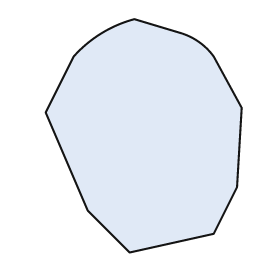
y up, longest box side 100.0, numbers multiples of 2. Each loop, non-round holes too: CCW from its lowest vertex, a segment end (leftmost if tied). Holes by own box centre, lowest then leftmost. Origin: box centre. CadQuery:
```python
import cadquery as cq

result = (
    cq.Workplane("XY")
    .moveTo(-6.0, -50.0)
    .lineTo(30.0, -42.0)
    .lineTo(40.0, -22.0)
    .lineTo(42.0, 12.0)
    .lineTo(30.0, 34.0)
    .threePointArc((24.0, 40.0), (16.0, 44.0))
    .lineTo(-4.0, 50.0)
    .threePointArc((-18.0, 44.0), (-30.0, 34.0))
    .lineTo(-42.0, 10.0)
    .lineTo(-24.0, -32.0)
    .close()
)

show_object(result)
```